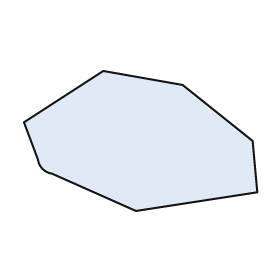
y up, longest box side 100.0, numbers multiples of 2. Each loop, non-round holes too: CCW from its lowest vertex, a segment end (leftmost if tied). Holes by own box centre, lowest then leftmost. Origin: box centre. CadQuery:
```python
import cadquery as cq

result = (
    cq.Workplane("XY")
    .moveTo(-2.0, -30.0)
    .lineTo(50.0, -22.0)
    .lineTo(48.0, 0.0)
    .lineTo(18.0, 24.0)
    .lineTo(-16.0, 30.0)
    .lineTo(-50.0, 8.0)
    .lineTo(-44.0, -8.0)
    .threePointArc((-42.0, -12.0), (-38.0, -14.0))
    .close()
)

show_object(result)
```